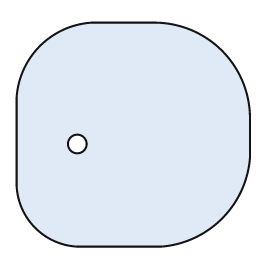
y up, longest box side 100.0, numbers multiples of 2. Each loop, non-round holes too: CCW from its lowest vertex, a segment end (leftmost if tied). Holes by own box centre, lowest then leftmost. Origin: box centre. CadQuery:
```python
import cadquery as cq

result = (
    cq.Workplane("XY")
    .moveTo(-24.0, -48.0)
    .lineTo(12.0, -48.0)
    .threePointArc((38.0, -36.0), (50.0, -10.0))
    .lineTo(50.0, 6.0)
    .threePointArc((38.0, 36.0), (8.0, 48.0))
    .lineTo(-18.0, 48.0)
    .threePointArc((-40.0, 38.0), (-50.0, 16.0))
    .lineTo(-50.0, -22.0)
    .threePointArc((-42.0, -40.0), (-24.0, -48.0))
    .close()
    .moveTo(-24.0, -4.0)
    .circle(4.0)
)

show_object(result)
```